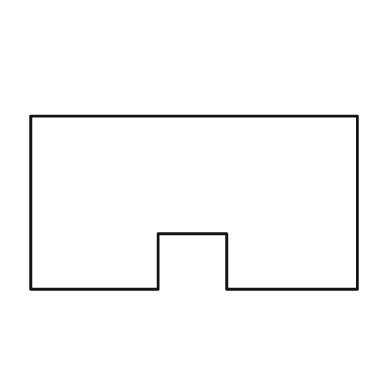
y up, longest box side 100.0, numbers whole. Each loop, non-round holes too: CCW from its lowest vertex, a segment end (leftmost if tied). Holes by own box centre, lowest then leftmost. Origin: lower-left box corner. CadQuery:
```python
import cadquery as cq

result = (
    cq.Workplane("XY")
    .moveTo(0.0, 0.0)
    .lineTo(39.0, 0.0)
    .lineTo(39.0, 17.0)
    .lineTo(60.0, 17.0)
    .lineTo(60.0, 0.0)
    .lineTo(100.0, 0.0)
    .lineTo(100.0, 53.0)
    .lineTo(0.0, 53.0)
    .close()
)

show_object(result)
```